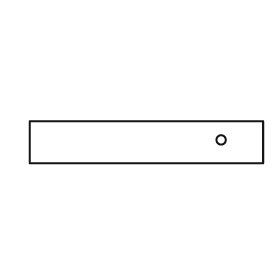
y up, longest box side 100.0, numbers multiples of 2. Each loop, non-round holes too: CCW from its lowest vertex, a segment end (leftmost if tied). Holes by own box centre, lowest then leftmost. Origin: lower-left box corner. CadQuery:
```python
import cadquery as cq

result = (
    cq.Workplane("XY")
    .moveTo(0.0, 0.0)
    .lineTo(100.0, 0.0)
    .lineTo(100.0, 18.0)
    .lineTo(0.0, 18.0)
    .close()
    .moveTo(82.0, 10.0)
    .circle(2.0)
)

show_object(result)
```